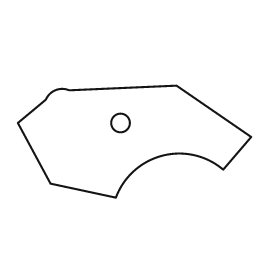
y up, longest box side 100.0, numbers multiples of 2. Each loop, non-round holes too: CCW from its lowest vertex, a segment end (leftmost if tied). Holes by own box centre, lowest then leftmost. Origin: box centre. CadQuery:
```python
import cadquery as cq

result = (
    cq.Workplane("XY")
    .moveTo(-8.0, -24.0)
    .threePointArc((12.0, -6.0), (38.0, -12.0))
    .lineTo(50.0, 2.0)
    .lineTo(18.0, 24.0)
    .lineTo(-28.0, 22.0)
    .threePointArc((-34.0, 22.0), (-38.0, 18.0))
    .lineTo(-50.0, 8.0)
    .lineTo(-36.0, -18.0)
    .close()
    .moveTo(-6.0, 8.0)
    .circle(4.0)
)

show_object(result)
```